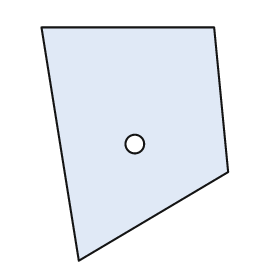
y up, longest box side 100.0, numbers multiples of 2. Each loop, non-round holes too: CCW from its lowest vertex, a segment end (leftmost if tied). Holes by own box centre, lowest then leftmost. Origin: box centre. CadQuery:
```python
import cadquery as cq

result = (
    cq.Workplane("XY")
    .moveTo(-24.0, -50.0)
    .lineTo(40.0, -12.0)
    .lineTo(34.0, 50.0)
    .lineTo(-40.0, 50.0)
    .close()
    .moveTo(0.0, 0.0)
    .circle(4.0)
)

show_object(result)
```